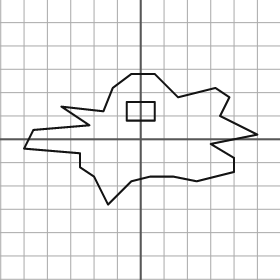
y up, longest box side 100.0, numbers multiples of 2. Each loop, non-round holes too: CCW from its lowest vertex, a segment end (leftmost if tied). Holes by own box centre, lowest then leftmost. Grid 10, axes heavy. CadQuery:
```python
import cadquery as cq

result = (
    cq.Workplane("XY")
    .moveTo(-14.0, -28.0)
    .lineTo(-4.0, -18.0)
    .lineTo(4.0, -16.0)
    .lineTo(14.0, -16.0)
    .lineTo(24.0, -18.0)
    .lineTo(40.0, -14.0)
    .lineTo(40.0, -8.0)
    .lineTo(30.0, -2.0)
    .lineTo(50.0, 2.0)
    .lineTo(34.0, 10.0)
    .lineTo(38.0, 18.0)
    .lineTo(32.0, 22.0)
    .lineTo(16.0, 18.0)
    .lineTo(6.0, 28.0)
    .lineTo(-4.0, 28.0)
    .lineTo(-12.0, 22.0)
    .lineTo(-16.0, 12.0)
    .lineTo(-34.0, 14.0)
    .lineTo(-22.0, 6.0)
    .lineTo(-46.0, 4.0)
    .lineTo(-50.0, -4.0)
    .lineTo(-26.0, -6.0)
    .lineTo(-26.0, -12.0)
    .lineTo(-20.0, -16.0)
    .close()
    .moveTo(-6.0, 8.0)
    .lineTo(6.0, 8.0)
    .lineTo(6.0, 16.0)
    .lineTo(-6.0, 16.0)
    .close()
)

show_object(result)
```